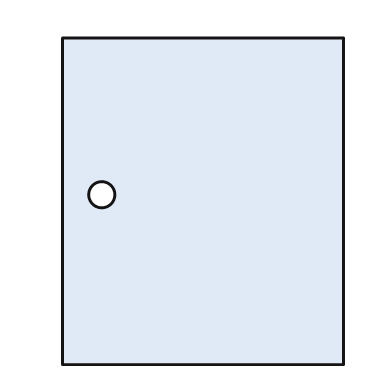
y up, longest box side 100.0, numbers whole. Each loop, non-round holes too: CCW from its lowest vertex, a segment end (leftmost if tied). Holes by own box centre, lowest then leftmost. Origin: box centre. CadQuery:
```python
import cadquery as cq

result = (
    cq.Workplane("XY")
    .moveTo(-43.0, -50.0)
    .lineTo(43.0, -50.0)
    .lineTo(43.0, 50.0)
    .lineTo(-43.0, 50.0)
    .close()
    .moveTo(-31.0, 2.0)
    .circle(4.0)
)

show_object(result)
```